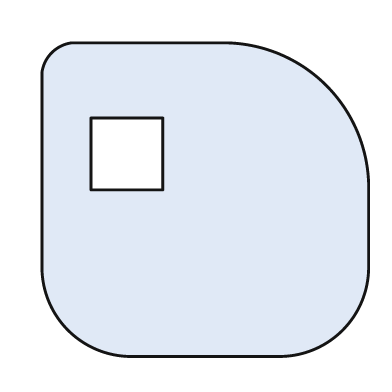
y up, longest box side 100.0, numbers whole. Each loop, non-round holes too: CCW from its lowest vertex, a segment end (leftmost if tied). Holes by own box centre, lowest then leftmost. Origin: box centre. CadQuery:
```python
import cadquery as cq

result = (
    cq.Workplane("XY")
    .moveTo(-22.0, -48.0)
    .lineTo(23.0, -48.0)
    .threePointArc((42.0, -40.0), (50.0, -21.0))
    .lineTo(50.0, 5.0)
    .threePointArc((37.0, 35.0), (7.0, 48.0))
    .lineTo(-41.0, 48.0)
    .threePointArc((-47.0, 45.0), (-50.0, 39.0))
    .lineTo(-50.0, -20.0)
    .threePointArc((-42.0, -40.0), (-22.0, -48.0))
    .close()
    .moveTo(-35.0, 3.0)
    .lineTo(-13.0, 3.0)
    .lineTo(-13.0, 25.0)
    .lineTo(-35.0, 25.0)
    .close()
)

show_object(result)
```